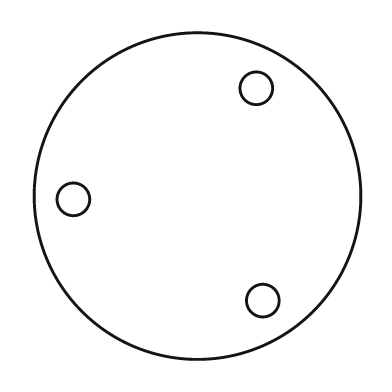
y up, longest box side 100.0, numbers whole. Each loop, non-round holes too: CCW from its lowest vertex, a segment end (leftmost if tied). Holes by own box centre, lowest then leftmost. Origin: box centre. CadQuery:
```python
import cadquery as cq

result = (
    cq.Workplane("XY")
    .moveTo(0.0, 0.0)
    .circle(50.0)
    .moveTo(20.0, -32.0)
    .circle(5.0)
    .moveTo(-38.0, -1.0)
    .circle(5.0)
    .moveTo(18.0, 33.0)
    .circle(5.0)
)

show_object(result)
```